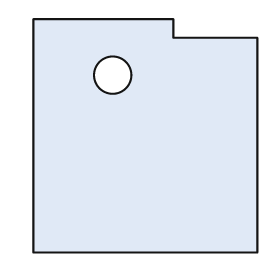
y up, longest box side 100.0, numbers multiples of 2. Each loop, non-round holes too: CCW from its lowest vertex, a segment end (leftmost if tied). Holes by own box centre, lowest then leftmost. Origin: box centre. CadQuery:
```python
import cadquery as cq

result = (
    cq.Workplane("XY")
    .moveTo(-48.0, -50.0)
    .lineTo(48.0, -50.0)
    .lineTo(48.0, 42.0)
    .lineTo(12.0, 42.0)
    .lineTo(12.0, 50.0)
    .lineTo(-48.0, 50.0)
    .close()
    .moveTo(-14.0, 26.0)
    .circle(8.0)
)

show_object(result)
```